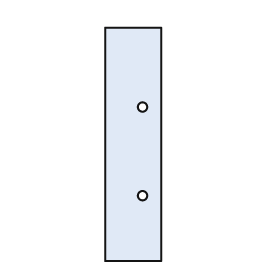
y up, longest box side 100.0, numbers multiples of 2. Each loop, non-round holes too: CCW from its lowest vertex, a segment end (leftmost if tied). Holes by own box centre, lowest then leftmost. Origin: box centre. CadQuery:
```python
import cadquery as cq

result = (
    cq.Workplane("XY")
    .moveTo(-12.0, -50.0)
    .lineTo(12.0, -50.0)
    .lineTo(12.0, 50.0)
    .lineTo(-12.0, 50.0)
    .close()
    .moveTo(4.0, -22.0)
    .circle(2.0)
    .moveTo(4.0, 16.0)
    .circle(2.0)
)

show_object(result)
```